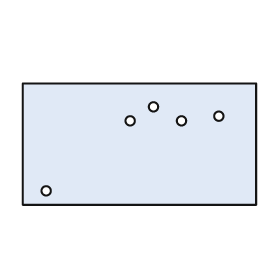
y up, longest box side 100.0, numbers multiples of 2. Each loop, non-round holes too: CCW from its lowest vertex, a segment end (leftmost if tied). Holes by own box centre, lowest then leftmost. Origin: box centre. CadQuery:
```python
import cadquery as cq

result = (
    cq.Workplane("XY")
    .moveTo(-50.0, -26.0)
    .lineTo(50.0, -26.0)
    .lineTo(50.0, 26.0)
    .lineTo(-50.0, 26.0)
    .close()
    .moveTo(-40.0, -20.0)
    .circle(2.0)
    .moveTo(-4.0, 10.0)
    .circle(2.0)
    .moveTo(18.0, 10.0)
    .circle(2.0)
    .moveTo(34.0, 12.0)
    .circle(2.0)
    .moveTo(6.0, 16.0)
    .circle(2.0)
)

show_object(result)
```